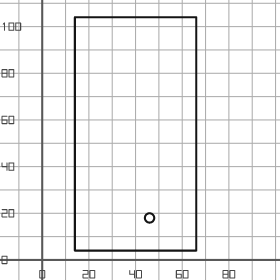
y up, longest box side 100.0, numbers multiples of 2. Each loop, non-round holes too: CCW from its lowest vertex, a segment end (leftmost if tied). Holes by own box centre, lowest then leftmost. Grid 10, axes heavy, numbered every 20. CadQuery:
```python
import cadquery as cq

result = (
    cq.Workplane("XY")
    .moveTo(14.0, 4.0)
    .lineTo(66.0, 4.0)
    .lineTo(66.0, 104.0)
    .lineTo(14.0, 104.0)
    .close()
    .moveTo(46.0, 18.0)
    .circle(2.0)
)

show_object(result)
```